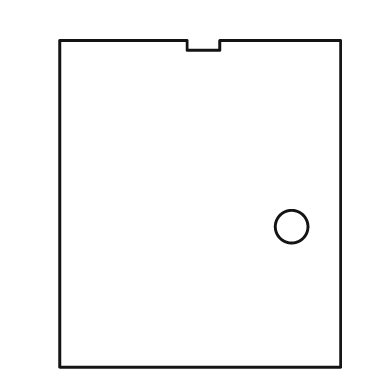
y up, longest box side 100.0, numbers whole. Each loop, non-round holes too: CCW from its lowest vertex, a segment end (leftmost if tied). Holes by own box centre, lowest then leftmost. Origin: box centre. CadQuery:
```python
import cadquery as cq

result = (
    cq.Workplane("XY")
    .moveTo(-43.0, -50.0)
    .lineTo(43.0, -50.0)
    .lineTo(43.0, 50.0)
    .lineTo(6.0, 50.0)
    .lineTo(6.0, 47.0)
    .lineTo(-4.0, 47.0)
    .lineTo(-4.0, 50.0)
    .lineTo(-43.0, 50.0)
    .close()
    .moveTo(28.0, -7.0)
    .circle(5.0)
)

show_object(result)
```